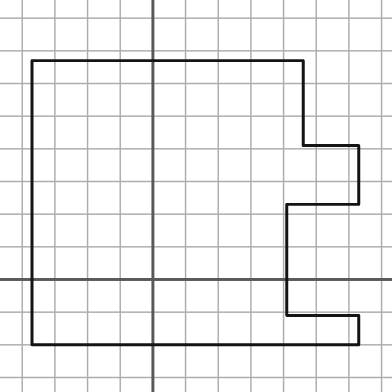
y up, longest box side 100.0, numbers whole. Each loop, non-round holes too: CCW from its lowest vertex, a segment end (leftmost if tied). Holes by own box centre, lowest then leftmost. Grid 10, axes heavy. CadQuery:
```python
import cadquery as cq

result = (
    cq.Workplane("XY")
    .moveTo(-37.0, -20.0)
    .lineTo(63.0, -20.0)
    .lineTo(63.0, -11.0)
    .lineTo(41.0, -11.0)
    .lineTo(41.0, 23.0)
    .lineTo(63.0, 23.0)
    .lineTo(63.0, 41.0)
    .lineTo(46.0, 41.0)
    .lineTo(46.0, 67.0)
    .lineTo(-37.0, 67.0)
    .close()
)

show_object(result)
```